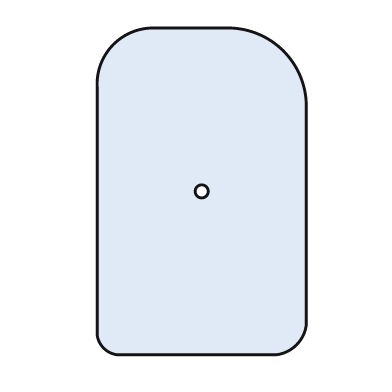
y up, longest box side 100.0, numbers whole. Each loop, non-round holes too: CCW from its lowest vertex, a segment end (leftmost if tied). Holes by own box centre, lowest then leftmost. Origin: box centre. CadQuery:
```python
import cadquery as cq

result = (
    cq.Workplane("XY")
    .moveTo(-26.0, -50.0)
    .lineTo(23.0, -50.0)
    .threePointArc((29.0, -47.0), (32.0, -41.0))
    .lineTo(32.0, 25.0)
    .threePointArc((25.0, 43.0), (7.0, 50.0))
    .lineTo(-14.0, 50.0)
    .threePointArc((-27.0, 45.0), (-32.0, 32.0))
    .lineTo(-32.0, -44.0)
    .threePointArc((-30.0, -48.0), (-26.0, -50.0))
    .close()
    .moveTo(0.0, 0.0)
    .circle(2.0)
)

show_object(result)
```